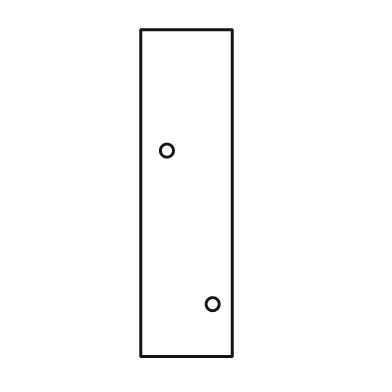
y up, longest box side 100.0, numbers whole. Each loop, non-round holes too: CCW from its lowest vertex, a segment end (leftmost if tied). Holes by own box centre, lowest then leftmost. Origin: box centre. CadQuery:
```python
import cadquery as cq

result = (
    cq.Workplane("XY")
    .moveTo(-14.0, -50.0)
    .lineTo(14.0, -50.0)
    .lineTo(14.0, 50.0)
    .lineTo(-14.0, 50.0)
    .close()
    .moveTo(8.0, -34.0)
    .circle(2.0)
    .moveTo(-6.0, 13.0)
    .circle(2.0)
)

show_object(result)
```